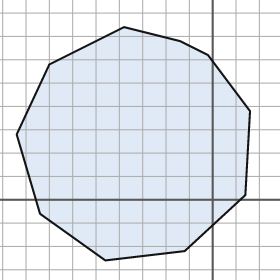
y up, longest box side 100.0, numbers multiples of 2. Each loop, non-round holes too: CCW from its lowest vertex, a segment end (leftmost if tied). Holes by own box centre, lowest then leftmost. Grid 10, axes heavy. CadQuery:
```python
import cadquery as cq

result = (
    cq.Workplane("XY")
    .moveTo(-46.0, -26.0)
    .lineTo(-12.0, -22.0)
    .lineTo(14.0, 2.0)
    .lineTo(16.0, 38.0)
    .lineTo(-2.0, 62.0)
    .lineTo(-14.0, 68.0)
    .lineTo(-38.0, 74.0)
    .lineTo(-70.0, 58.0)
    .lineTo(-84.0, 28.0)
    .lineTo(-74.0, -6.0)
    .close()
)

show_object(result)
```